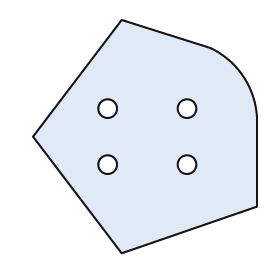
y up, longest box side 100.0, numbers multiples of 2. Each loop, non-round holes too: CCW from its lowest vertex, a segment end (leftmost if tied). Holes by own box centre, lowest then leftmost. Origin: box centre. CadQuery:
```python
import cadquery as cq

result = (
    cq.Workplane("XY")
    .moveTo(-10.0, -50.0)
    .lineTo(48.0, -30.0)
    .lineTo(48.0, 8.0)
    .threePointArc((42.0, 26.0), (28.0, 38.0))
    .lineTo(-10.0, 50.0)
    .lineTo(-48.0, 0.0)
    .close()
    .moveTo(-16.0, -12.0)
    .circle(4.0)
    .moveTo(18.0, -12.0)
    .circle(4.0)
    .moveTo(-16.0, 12.0)
    .circle(4.0)
    .moveTo(18.0, 12.0)
    .circle(4.0)
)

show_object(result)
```